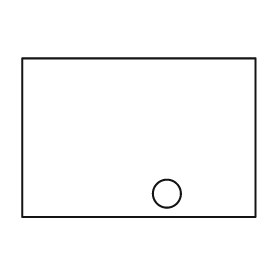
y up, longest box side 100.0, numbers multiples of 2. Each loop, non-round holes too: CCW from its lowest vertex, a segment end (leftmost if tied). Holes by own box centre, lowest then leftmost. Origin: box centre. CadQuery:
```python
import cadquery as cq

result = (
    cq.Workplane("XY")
    .moveTo(-50.0, -34.0)
    .lineTo(50.0, -34.0)
    .lineTo(50.0, 34.0)
    .lineTo(-50.0, 34.0)
    .close()
    .moveTo(12.0, -24.0)
    .circle(6.0)
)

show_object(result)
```